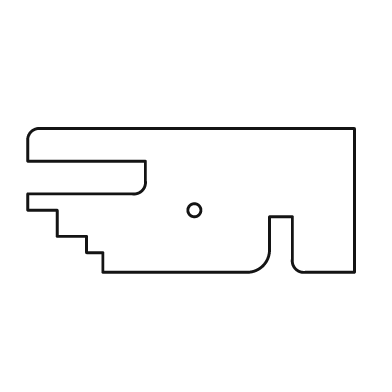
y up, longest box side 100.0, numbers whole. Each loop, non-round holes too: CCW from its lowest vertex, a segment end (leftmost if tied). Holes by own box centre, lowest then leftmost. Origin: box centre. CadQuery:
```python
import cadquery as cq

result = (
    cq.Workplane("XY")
    .moveTo(-27.0, -22.0)
    .lineTo(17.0, -22.0)
    .threePointArc((22.0, -20.0), (24.0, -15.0))
    .lineTo(24.0, -5.0)
    .lineTo(31.0, -5.0)
    .lineTo(31.0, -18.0)
    .threePointArc((32.0, -21.0), (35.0, -22.0))
    .lineTo(50.0, -22.0)
    .lineTo(50.0, 22.0)
    .lineTo(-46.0, 22.0)
    .threePointArc((-49.0, 21.0), (-50.0, 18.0))
    .lineTo(-50.0, 12.0)
    .lineTo(-14.0, 12.0)
    .lineTo(-14.0, 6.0)
    .threePointArc((-15.0, 3.0), (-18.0, 2.0))
    .lineTo(-50.0, 2.0)
    .lineTo(-50.0, -3.0)
    .lineTo(-41.0, -3.0)
    .lineTo(-41.0, -11.0)
    .lineTo(-32.0, -11.0)
    .lineTo(-32.0, -16.0)
    .lineTo(-27.0, -16.0)
    .close()
    .moveTo(1.0, -3.0)
    .circle(2.0)
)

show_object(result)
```